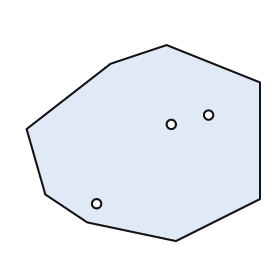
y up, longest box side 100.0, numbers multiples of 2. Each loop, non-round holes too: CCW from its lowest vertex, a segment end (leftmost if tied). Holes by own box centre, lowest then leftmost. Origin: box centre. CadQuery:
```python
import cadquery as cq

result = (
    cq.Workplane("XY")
    .moveTo(14.0, -42.0)
    .lineTo(50.0, -24.0)
    .lineTo(50.0, 26.0)
    .lineTo(10.0, 42.0)
    .lineTo(-14.0, 34.0)
    .lineTo(-50.0, 6.0)
    .lineTo(-42.0, -22.0)
    .lineTo(-24.0, -34.0)
    .close()
    .moveTo(-20.0, -26.0)
    .circle(2.0)
    .moveTo(12.0, 8.0)
    .circle(2.0)
    .moveTo(28.0, 12.0)
    .circle(2.0)
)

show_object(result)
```